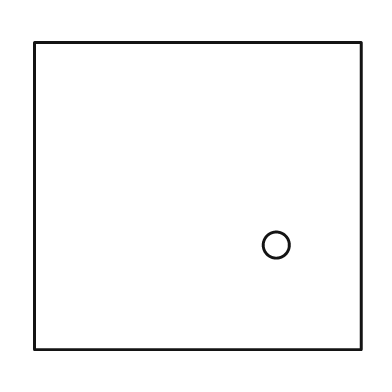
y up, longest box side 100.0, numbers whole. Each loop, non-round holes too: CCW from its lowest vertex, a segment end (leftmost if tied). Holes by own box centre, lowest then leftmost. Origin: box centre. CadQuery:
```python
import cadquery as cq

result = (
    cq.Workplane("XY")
    .moveTo(-50.0, -47.0)
    .lineTo(50.0, -47.0)
    .lineTo(50.0, 47.0)
    .lineTo(-50.0, 47.0)
    .close()
    .moveTo(24.0, -15.0)
    .circle(4.0)
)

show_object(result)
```